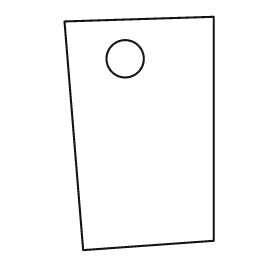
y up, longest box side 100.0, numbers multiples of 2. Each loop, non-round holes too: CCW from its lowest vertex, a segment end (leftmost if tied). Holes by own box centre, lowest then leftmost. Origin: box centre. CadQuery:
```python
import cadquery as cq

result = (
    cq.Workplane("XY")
    .moveTo(-24.0, -50.0)
    .lineTo(32.0, -46.0)
    .lineTo(32.0, 50.0)
    .lineTo(-32.0, 48.0)
    .close()
    .moveTo(-6.0, 32.0)
    .circle(8.0)
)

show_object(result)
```